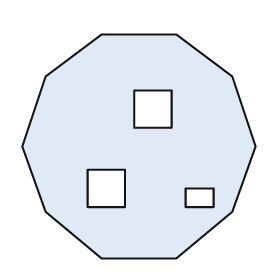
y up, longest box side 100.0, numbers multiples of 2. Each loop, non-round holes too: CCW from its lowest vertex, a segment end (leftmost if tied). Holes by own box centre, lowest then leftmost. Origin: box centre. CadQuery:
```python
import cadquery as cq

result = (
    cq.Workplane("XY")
    .moveTo(-16.0, -48.0)
    .lineTo(16.0, -48.0)
    .lineTo(40.0, -28.0)
    .lineTo(50.0, 0.0)
    .lineTo(40.0, 30.0)
    .lineTo(16.0, 48.0)
    .lineTo(-16.0, 48.0)
    .lineTo(-40.0, 30.0)
    .lineTo(-50.0, 0.0)
    .lineTo(-40.0, -28.0)
    .close()
    .moveTo(20.0, -26.0)
    .lineTo(32.0, -26.0)
    .lineTo(32.0, -18.0)
    .lineTo(20.0, -18.0)
    .close()
    .moveTo(-22.0, -26.0)
    .lineTo(-6.0, -26.0)
    .lineTo(-6.0, -10.0)
    .lineTo(-22.0, -10.0)
    .close()
    .moveTo(-2.0, 8.0)
    .lineTo(14.0, 8.0)
    .lineTo(14.0, 24.0)
    .lineTo(-2.0, 24.0)
    .close()
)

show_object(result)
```